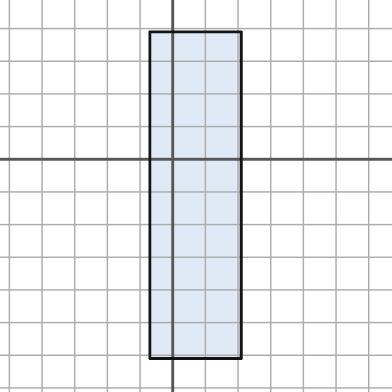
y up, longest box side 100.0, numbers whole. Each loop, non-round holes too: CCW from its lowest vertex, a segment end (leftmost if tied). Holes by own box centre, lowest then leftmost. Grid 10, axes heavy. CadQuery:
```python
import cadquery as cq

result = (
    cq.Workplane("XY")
    .moveTo(-7.0, -61.0)
    .lineTo(21.0, -61.0)
    .lineTo(21.0, 39.0)
    .lineTo(-7.0, 39.0)
    .close()
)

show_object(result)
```